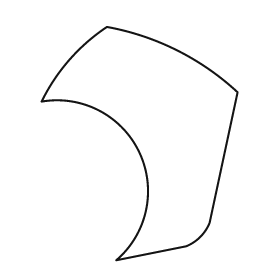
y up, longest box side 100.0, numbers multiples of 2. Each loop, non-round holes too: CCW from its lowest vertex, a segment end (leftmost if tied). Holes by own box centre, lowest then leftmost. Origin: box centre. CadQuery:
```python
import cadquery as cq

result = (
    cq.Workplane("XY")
    .moveTo(-10.0, -50.0)
    .lineTo(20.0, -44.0)
    .threePointArc((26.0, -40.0), (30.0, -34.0))
    .lineTo(42.0, 22.0)
    .threePointArc((16.0, 40.0), (-14.0, 50.0))
    .threePointArc((-30.0, 36.0), (-42.0, 18.0))
    .threePointArc((0.0, -4.0), (-10.0, -50.0))
    .close()
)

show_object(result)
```